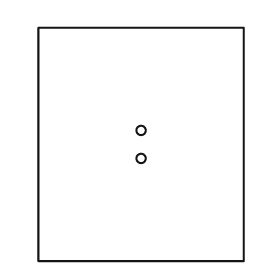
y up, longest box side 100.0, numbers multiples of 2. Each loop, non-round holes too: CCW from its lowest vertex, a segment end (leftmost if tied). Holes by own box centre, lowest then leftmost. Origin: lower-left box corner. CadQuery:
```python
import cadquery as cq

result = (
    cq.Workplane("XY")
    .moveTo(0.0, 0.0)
    .lineTo(88.0, 0.0)
    .lineTo(88.0, 100.0)
    .lineTo(0.0, 100.0)
    .close()
    .moveTo(44.0, 44.0)
    .circle(2.0)
    .moveTo(44.0, 56.0)
    .circle(2.0)
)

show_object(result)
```